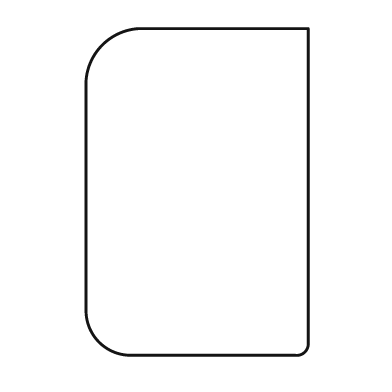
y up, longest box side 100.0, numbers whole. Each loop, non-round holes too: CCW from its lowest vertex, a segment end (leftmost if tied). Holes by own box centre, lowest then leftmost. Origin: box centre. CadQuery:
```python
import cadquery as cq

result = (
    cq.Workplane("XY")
    .moveTo(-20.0, -50.0)
    .lineTo(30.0, -50.0)
    .threePointArc((33.0, -49.0), (34.0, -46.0))
    .lineTo(34.0, 50.0)
    .lineTo(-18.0, 50.0)
    .threePointArc((-29.0, 45.0), (-34.0, 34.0))
    .lineTo(-34.0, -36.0)
    .threePointArc((-30.0, -46.0), (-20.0, -50.0))
    .close()
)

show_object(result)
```